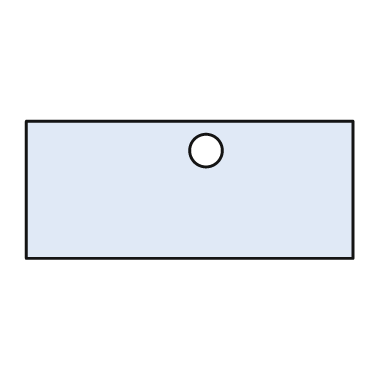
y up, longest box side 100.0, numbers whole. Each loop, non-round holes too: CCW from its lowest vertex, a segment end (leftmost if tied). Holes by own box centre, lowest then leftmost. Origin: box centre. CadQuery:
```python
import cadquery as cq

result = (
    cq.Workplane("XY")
    .moveTo(-50.0, -21.0)
    .lineTo(50.0, -21.0)
    .lineTo(50.0, 21.0)
    .lineTo(-50.0, 21.0)
    .close()
    .moveTo(5.0, 12.0)
    .circle(5.0)
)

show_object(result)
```